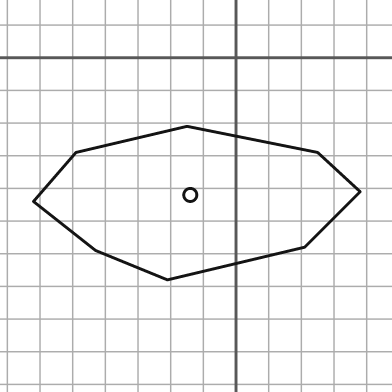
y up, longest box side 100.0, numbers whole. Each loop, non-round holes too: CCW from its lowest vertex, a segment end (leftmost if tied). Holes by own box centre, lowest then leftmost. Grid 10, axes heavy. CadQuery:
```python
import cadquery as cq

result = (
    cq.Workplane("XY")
    .moveTo(-21.0, -68.0)
    .lineTo(21.0, -58.0)
    .lineTo(38.0, -41.0)
    .lineTo(25.0, -29.0)
    .lineTo(-15.0, -21.0)
    .lineTo(-49.0, -29.0)
    .lineTo(-62.0, -44.0)
    .lineTo(-43.0, -59.0)
    .close()
    .moveTo(-14.0, -42.0)
    .circle(2.0)
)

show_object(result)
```